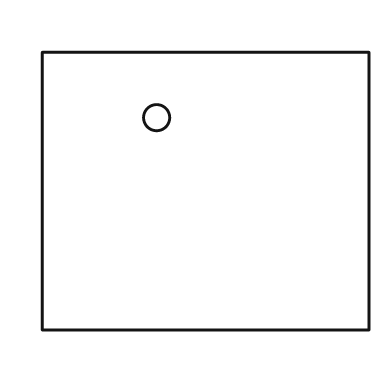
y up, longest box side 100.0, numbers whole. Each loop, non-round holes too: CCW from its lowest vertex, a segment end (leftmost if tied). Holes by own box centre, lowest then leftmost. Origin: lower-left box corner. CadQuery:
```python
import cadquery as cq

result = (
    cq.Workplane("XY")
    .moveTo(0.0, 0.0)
    .lineTo(100.0, 0.0)
    .lineTo(100.0, 85.0)
    .lineTo(0.0, 85.0)
    .close()
    .moveTo(35.0, 65.0)
    .circle(4.0)
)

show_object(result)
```